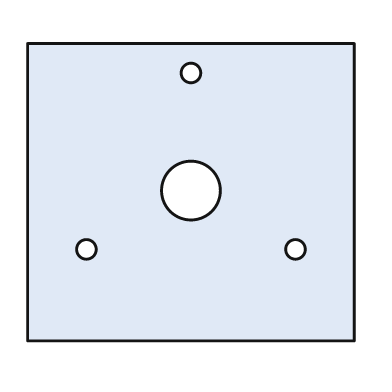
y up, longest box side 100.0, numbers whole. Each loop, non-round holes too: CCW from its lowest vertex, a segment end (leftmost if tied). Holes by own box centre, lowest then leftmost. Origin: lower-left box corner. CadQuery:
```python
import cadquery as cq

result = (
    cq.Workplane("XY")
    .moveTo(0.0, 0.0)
    .lineTo(100.0, 0.0)
    .lineTo(100.0, 91.0)
    .lineTo(0.0, 91.0)
    .close()
    .moveTo(18.0, 28.0)
    .circle(3.0)
    .moveTo(82.0, 28.0)
    .circle(3.0)
    .moveTo(50.0, 46.0)
    .circle(9.0)
    .moveTo(50.0, 82.0)
    .circle(3.0)
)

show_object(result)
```